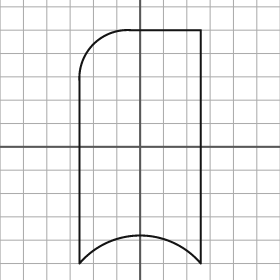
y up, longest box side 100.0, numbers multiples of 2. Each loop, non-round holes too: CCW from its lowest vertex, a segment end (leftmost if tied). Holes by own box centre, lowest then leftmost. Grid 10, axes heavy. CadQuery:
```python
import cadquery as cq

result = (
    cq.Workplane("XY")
    .moveTo(-26.0, -50.0)
    .threePointArc((0.0, -38.0), (26.0, -50.0))
    .lineTo(26.0, 50.0)
    .lineTo(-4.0, 50.0)
    .threePointArc((-20.0, 44.0), (-26.0, 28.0))
    .close()
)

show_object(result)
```